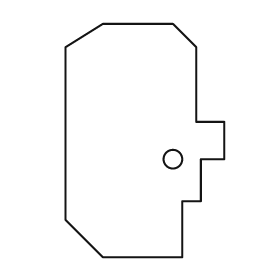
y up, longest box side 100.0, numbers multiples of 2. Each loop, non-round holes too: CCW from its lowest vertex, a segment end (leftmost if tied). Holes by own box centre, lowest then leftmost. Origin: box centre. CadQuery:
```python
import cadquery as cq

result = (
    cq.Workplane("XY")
    .moveTo(-18.0, -50.0)
    .lineTo(16.0, -50.0)
    .lineTo(16.0, -26.0)
    .lineTo(24.0, -26.0)
    .lineTo(24.0, -8.0)
    .lineTo(34.0, -8.0)
    .lineTo(34.0, 8.0)
    .lineTo(22.0, 8.0)
    .lineTo(22.0, 40.0)
    .lineTo(12.0, 50.0)
    .lineTo(-18.0, 50.0)
    .lineTo(-34.0, 40.0)
    .lineTo(-34.0, -34.0)
    .close()
    .moveTo(12.0, -8.0)
    .circle(4.0)
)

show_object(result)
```